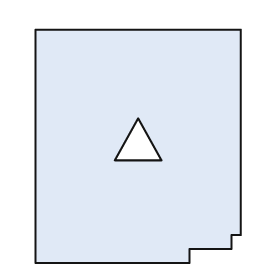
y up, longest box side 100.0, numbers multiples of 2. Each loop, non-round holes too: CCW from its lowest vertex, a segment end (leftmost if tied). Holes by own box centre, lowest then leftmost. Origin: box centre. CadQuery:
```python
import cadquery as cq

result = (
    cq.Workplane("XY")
    .moveTo(-44.0, -50.0)
    .lineTo(22.0, -50.0)
    .lineTo(22.0, -44.0)
    .lineTo(40.0, -44.0)
    .lineTo(40.0, -38.0)
    .lineTo(44.0, -38.0)
    .lineTo(44.0, 50.0)
    .lineTo(-44.0, 50.0)
    .close()
    .moveTo(-10.0, -6.0)
    .lineTo(10.0, -6.0)
    .lineTo(0.0, 12.0)
    .close()
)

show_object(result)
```